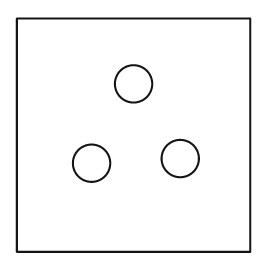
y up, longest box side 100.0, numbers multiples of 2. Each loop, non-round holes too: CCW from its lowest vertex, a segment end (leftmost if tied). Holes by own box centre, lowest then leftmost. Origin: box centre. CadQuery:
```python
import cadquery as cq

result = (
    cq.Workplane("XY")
    .moveTo(-50.0, -50.0)
    .lineTo(50.0, -50.0)
    .lineTo(50.0, 50.0)
    .lineTo(-50.0, 50.0)
    .close()
    .moveTo(-18.0, -12.0)
    .circle(8.0)
    .moveTo(20.0, -10.0)
    .circle(8.0)
    .moveTo(0.0, 22.0)
    .circle(8.0)
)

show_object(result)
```